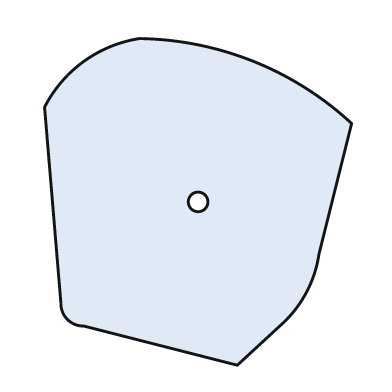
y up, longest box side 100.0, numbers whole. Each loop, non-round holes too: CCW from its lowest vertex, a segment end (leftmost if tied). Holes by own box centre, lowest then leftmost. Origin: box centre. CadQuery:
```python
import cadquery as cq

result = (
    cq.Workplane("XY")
    .moveTo(12.0, -50.0)
    .lineTo(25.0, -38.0)
    .threePointArc((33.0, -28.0), (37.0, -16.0))
    .lineTo(47.0, 24.0)
    .threePointArc((17.0, 43.0), (-18.0, 50.0))
    .threePointArc((-35.0, 43.0), (-47.0, 29.0))
    .lineTo(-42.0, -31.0)
    .threePointArc((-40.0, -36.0), (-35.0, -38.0))
    .close()
    .moveTo(0.0, 0.0)
    .circle(3.0)
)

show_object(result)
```